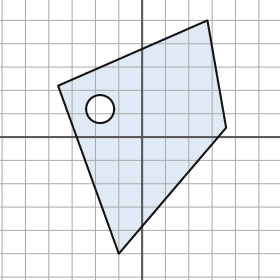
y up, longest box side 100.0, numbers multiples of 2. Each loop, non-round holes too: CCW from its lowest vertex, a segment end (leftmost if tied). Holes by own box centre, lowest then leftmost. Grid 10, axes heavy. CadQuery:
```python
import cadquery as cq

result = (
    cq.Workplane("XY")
    .moveTo(-10.0, -50.0)
    .lineTo(36.0, 4.0)
    .lineTo(28.0, 50.0)
    .lineTo(-36.0, 22.0)
    .close()
    .moveTo(-18.0, 12.0)
    .circle(6.0)
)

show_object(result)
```